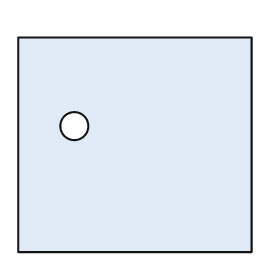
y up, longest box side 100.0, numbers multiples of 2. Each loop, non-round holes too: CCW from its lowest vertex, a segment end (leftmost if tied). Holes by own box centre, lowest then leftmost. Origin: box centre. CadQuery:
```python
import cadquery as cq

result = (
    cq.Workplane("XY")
    .moveTo(-50.0, -46.0)
    .lineTo(50.0, -46.0)
    .lineTo(50.0, 46.0)
    .lineTo(-50.0, 46.0)
    .close()
    .moveTo(-26.0, 8.0)
    .circle(6.0)
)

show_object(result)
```